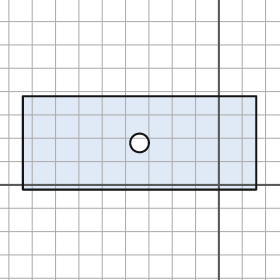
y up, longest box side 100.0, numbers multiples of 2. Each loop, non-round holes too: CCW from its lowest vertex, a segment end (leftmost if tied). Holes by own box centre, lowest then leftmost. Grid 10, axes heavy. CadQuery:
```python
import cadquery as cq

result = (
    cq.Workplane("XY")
    .moveTo(-84.0, -2.0)
    .lineTo(16.0, -2.0)
    .lineTo(16.0, 38.0)
    .lineTo(-84.0, 38.0)
    .close()
    .moveTo(-34.0, 18.0)
    .circle(4.0)
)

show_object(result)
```